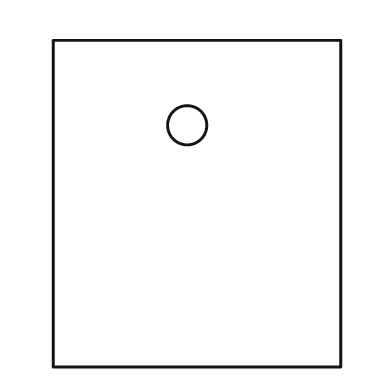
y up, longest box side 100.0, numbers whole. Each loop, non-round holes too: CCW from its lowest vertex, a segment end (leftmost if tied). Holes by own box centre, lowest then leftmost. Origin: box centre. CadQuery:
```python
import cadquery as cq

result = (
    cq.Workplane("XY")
    .moveTo(-44.0, -50.0)
    .lineTo(44.0, -50.0)
    .lineTo(44.0, 50.0)
    .lineTo(-44.0, 50.0)
    .close()
    .moveTo(-3.0, 24.0)
    .circle(6.0)
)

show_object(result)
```